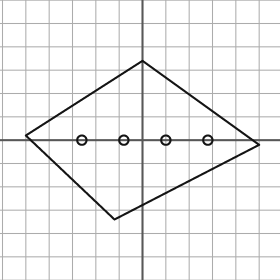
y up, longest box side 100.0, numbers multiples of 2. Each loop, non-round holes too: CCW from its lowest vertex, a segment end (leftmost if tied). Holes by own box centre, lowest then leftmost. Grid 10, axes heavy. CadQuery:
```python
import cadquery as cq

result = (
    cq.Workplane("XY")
    .moveTo(-12.0, -34.0)
    .lineTo(50.0, -2.0)
    .lineTo(0.0, 34.0)
    .lineTo(-50.0, 2.0)
    .close()
    .moveTo(-26.0, 0.0)
    .circle(2.0)
    .moveTo(-8.0, 0.0)
    .circle(2.0)
    .moveTo(10.0, 0.0)
    .circle(2.0)
    .moveTo(28.0, 0.0)
    .circle(2.0)
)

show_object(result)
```